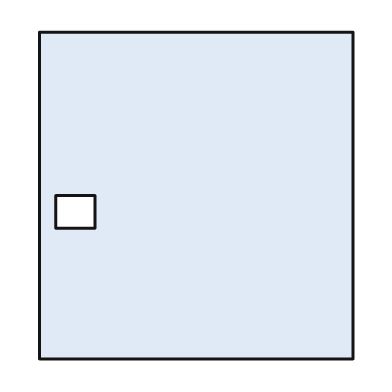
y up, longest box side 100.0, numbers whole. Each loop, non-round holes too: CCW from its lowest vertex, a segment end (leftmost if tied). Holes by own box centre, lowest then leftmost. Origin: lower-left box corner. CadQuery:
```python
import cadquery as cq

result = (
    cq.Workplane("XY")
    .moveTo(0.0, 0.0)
    .lineTo(96.0, 0.0)
    .lineTo(96.0, 100.0)
    .lineTo(0.0, 100.0)
    .close()
    .moveTo(5.0, 40.0)
    .lineTo(17.0, 40.0)
    .lineTo(17.0, 50.0)
    .lineTo(5.0, 50.0)
    .close()
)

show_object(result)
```